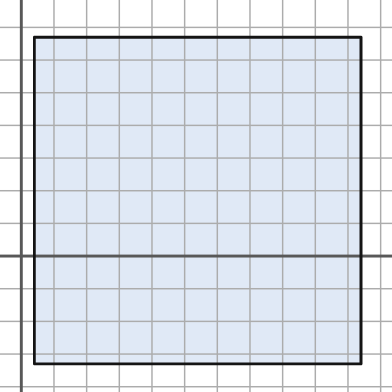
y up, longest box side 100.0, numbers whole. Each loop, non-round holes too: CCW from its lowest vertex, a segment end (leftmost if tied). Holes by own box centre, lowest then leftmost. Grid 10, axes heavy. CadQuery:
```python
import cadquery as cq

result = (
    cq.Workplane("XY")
    .moveTo(4.0, -33.0)
    .lineTo(104.0, -33.0)
    .lineTo(104.0, 67.0)
    .lineTo(4.0, 67.0)
    .close()
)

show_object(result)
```